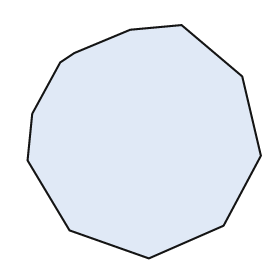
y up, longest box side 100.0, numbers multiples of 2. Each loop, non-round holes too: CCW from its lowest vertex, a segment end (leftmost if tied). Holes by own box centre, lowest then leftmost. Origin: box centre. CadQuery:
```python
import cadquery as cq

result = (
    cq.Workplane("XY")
    .moveTo(2.0, -50.0)
    .lineTo(34.0, -36.0)
    .lineTo(50.0, -6.0)
    .lineTo(42.0, 28.0)
    .lineTo(16.0, 50.0)
    .lineTo(-6.0, 48.0)
    .lineTo(-30.0, 38.0)
    .lineTo(-36.0, 34.0)
    .lineTo(-48.0, 12.0)
    .lineTo(-50.0, -8.0)
    .lineTo(-32.0, -38.0)
    .close()
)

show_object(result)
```